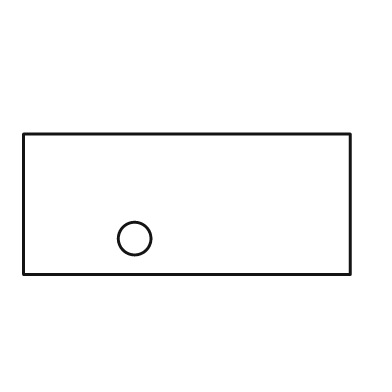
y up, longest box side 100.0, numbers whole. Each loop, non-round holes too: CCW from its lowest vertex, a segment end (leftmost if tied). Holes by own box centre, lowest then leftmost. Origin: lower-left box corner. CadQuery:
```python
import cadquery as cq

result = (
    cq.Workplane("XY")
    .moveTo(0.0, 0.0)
    .lineTo(100.0, 0.0)
    .lineTo(100.0, 43.0)
    .lineTo(0.0, 43.0)
    .close()
    .moveTo(34.0, 11.0)
    .circle(5.0)
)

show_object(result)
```